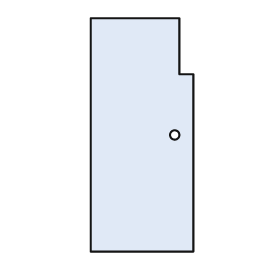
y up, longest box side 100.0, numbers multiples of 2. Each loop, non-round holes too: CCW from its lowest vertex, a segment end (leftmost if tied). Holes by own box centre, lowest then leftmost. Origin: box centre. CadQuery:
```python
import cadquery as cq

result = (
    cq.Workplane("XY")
    .moveTo(-22.0, -50.0)
    .lineTo(22.0, -50.0)
    .lineTo(22.0, 26.0)
    .lineTo(16.0, 26.0)
    .lineTo(16.0, 50.0)
    .lineTo(-22.0, 50.0)
    .close()
    .moveTo(14.0, 0.0)
    .circle(2.0)
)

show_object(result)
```